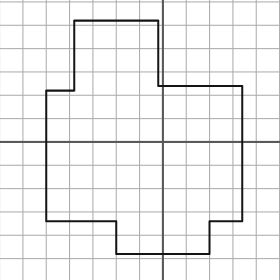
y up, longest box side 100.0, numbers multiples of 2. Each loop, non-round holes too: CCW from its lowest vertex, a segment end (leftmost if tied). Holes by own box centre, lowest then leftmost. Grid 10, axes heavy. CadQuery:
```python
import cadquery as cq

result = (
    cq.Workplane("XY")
    .moveTo(-20.0, -48.0)
    .lineTo(20.0, -48.0)
    .lineTo(20.0, -34.0)
    .lineTo(34.0, -34.0)
    .lineTo(34.0, 24.0)
    .lineTo(-2.0, 24.0)
    .lineTo(-2.0, 52.0)
    .lineTo(-38.0, 52.0)
    .lineTo(-38.0, 22.0)
    .lineTo(-50.0, 22.0)
    .lineTo(-50.0, -34.0)
    .lineTo(-20.0, -34.0)
    .close()
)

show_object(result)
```